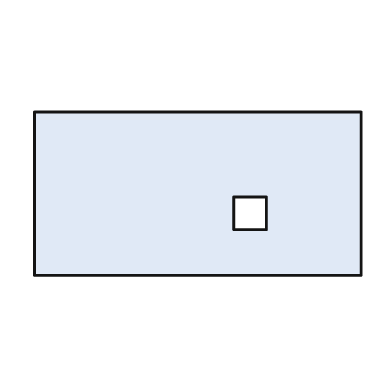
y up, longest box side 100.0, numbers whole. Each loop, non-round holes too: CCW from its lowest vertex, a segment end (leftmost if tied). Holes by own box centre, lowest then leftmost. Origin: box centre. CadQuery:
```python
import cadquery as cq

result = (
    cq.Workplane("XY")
    .moveTo(-50.0, -25.0)
    .lineTo(50.0, -25.0)
    .lineTo(50.0, 25.0)
    .lineTo(-50.0, 25.0)
    .close()
    .moveTo(11.0, -11.0)
    .lineTo(21.0, -11.0)
    .lineTo(21.0, -1.0)
    .lineTo(11.0, -1.0)
    .close()
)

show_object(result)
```